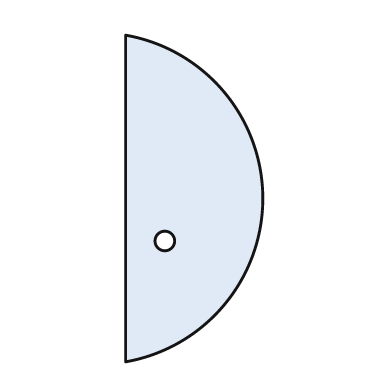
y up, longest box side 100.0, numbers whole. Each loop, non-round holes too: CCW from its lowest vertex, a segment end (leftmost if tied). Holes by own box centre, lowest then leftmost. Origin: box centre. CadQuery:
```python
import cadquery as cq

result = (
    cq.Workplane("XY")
    .moveTo(-21.0, -50.0)
    .threePointArc((21.0, 0.0), (-21.0, 50.0))
    .close()
    .moveTo(-9.0, -13.0)
    .circle(3.0)
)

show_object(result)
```